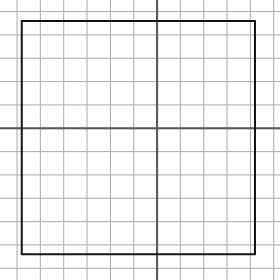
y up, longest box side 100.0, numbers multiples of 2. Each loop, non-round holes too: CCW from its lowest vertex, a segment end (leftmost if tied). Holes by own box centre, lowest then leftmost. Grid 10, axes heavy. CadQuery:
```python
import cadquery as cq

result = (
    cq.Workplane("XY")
    .moveTo(-58.0, -54.0)
    .lineTo(42.0, -54.0)
    .lineTo(42.0, 46.0)
    .lineTo(-58.0, 46.0)
    .close()
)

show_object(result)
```